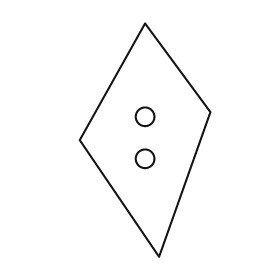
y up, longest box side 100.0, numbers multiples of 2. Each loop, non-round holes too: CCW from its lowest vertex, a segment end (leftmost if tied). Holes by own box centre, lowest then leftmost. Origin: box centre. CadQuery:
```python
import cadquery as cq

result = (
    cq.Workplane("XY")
    .moveTo(6.0, -50.0)
    .lineTo(28.0, 12.0)
    .lineTo(0.0, 50.0)
    .lineTo(-28.0, 0.0)
    .close()
    .moveTo(0.0, -8.0)
    .circle(4.0)
    .moveTo(0.0, 10.0)
    .circle(4.0)
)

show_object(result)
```